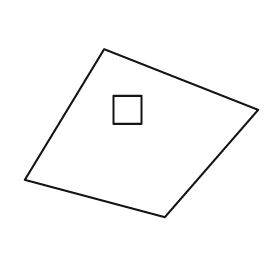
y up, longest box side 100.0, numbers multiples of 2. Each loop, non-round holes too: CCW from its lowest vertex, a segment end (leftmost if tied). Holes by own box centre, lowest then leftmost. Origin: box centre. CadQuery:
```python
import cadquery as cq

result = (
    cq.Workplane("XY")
    .moveTo(10.0, -36.0)
    .lineTo(50.0, 10.0)
    .lineTo(-16.0, 36.0)
    .lineTo(-50.0, -20.0)
    .close()
    .moveTo(-12.0, 4.0)
    .lineTo(0.0, 4.0)
    .lineTo(0.0, 16.0)
    .lineTo(-12.0, 16.0)
    .close()
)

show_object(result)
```